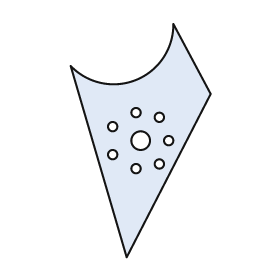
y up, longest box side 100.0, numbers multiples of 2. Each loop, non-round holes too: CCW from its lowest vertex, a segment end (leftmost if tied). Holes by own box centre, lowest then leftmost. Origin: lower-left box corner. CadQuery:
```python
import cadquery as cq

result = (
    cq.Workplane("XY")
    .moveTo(24.0, 0.0)
    .lineTo(60.0, 70.0)
    .lineTo(44.0, 100.0)
    .threePointArc((28.0, 76.0), (0.0, 82.0))
    .close()
    .moveTo(28.0, 38.0)
    .circle(2.0)
    .moveTo(38.0, 40.0)
    .circle(2.0)
    .moveTo(18.0, 44.0)
    .circle(2.0)
    .moveTo(30.0, 50.0)
    .circle(4.0)
    .moveTo(42.0, 50.0)
    .circle(2.0)
    .moveTo(18.0, 56.0)
    .circle(2.0)
    .moveTo(38.0, 60.0)
    .circle(2.0)
    .moveTo(28.0, 62.0)
    .circle(2.0)
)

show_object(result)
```